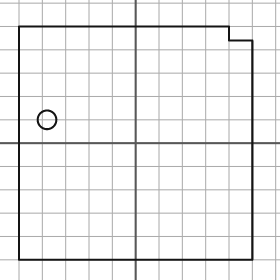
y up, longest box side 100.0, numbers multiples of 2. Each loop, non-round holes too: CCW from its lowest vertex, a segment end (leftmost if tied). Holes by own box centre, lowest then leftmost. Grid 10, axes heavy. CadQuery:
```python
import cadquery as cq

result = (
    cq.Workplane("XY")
    .moveTo(-50.0, -50.0)
    .lineTo(50.0, -50.0)
    .lineTo(50.0, 44.0)
    .lineTo(40.0, 44.0)
    .lineTo(40.0, 50.0)
    .lineTo(-50.0, 50.0)
    .close()
    .moveTo(-38.0, 10.0)
    .circle(4.0)
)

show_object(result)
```